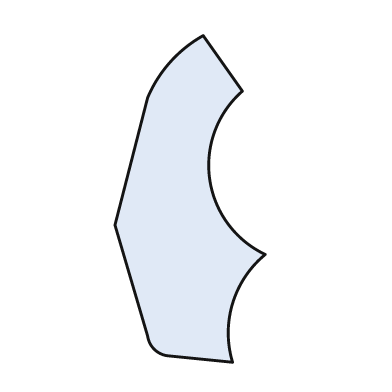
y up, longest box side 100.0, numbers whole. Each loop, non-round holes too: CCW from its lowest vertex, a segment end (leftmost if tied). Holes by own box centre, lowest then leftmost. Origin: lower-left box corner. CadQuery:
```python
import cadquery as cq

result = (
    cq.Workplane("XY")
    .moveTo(36.0, 0.0)
    .threePointArc((36.0, 18.0), (46.0, 33.0))
    .threePointArc((29.0, 56.0), (39.0, 83.0))
    .lineTo(27.0, 100.0)
    .threePointArc((17.0, 92.0), (10.0, 81.0))
    .lineTo(0.0, 42.0)
    .lineTo(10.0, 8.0)
    .threePointArc((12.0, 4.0), (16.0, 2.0))
    .close()
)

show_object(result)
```